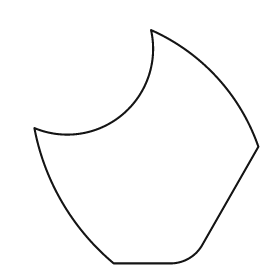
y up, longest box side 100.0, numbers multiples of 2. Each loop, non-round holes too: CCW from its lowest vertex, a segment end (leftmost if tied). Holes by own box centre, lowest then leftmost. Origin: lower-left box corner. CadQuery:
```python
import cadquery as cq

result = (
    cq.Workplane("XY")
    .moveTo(34.0, 0.0)
    .lineTo(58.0, 0.0)
    .threePointArc((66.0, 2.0), (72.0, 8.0))
    .lineTo(96.0, 50.0)
    .threePointArc((78.0, 80.0), (50.0, 100.0))
    .threePointArc((38.0, 64.0), (0.0, 58.0))
    .threePointArc((12.0, 26.0), (34.0, 0.0))
    .close()
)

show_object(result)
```